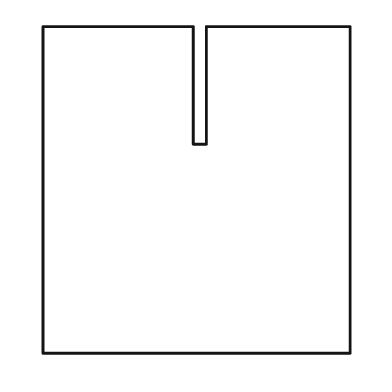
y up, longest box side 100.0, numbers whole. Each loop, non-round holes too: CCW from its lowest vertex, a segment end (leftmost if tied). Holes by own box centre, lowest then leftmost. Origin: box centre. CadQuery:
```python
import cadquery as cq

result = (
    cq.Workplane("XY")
    .moveTo(-47.0, -50.0)
    .lineTo(47.0, -50.0)
    .lineTo(47.0, 50.0)
    .lineTo(3.0, 50.0)
    .lineTo(3.0, 14.0)
    .lineTo(-1.0, 14.0)
    .lineTo(-1.0, 50.0)
    .lineTo(-47.0, 50.0)
    .close()
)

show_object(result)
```